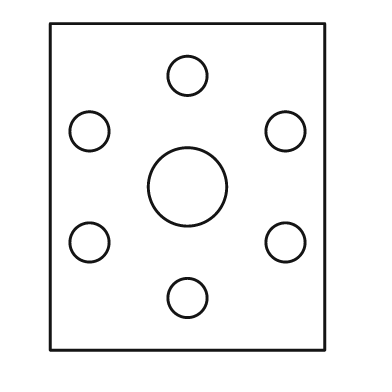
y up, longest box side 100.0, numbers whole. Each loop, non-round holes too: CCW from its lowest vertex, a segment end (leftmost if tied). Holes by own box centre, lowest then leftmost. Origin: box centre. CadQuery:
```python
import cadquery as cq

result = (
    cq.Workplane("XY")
    .moveTo(-42.0, -50.0)
    .lineTo(42.0, -50.0)
    .lineTo(42.0, 50.0)
    .lineTo(-42.0, 50.0)
    .close()
    .moveTo(0.0, -34.0)
    .circle(6.0)
    .moveTo(-30.0, -17.0)
    .circle(6.0)
    .moveTo(30.0, -17.0)
    .circle(6.0)
    .moveTo(0.0, 0.0)
    .circle(12.0)
    .moveTo(-30.0, 17.0)
    .circle(6.0)
    .moveTo(30.0, 17.0)
    .circle(6.0)
    .moveTo(0.0, 34.0)
    .circle(6.0)
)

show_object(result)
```